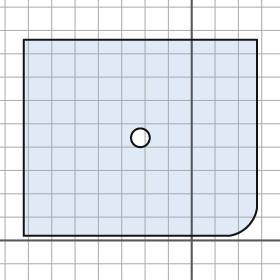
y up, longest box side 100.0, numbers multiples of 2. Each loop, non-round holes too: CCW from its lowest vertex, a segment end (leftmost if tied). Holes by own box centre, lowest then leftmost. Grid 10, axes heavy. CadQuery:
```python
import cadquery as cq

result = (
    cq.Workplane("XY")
    .moveTo(-72.0, 2.0)
    .lineTo(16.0, 2.0)
    .threePointArc((24.0, 6.0), (28.0, 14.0))
    .lineTo(28.0, 86.0)
    .lineTo(-72.0, 86.0)
    .close()
    .moveTo(-22.0, 44.0)
    .circle(4.0)
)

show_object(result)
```